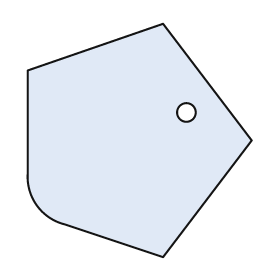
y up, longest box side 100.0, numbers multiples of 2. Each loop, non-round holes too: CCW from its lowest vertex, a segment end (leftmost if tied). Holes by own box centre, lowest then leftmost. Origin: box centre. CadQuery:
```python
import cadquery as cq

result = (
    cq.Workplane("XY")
    .moveTo(10.0, -50.0)
    .lineTo(48.0, 0.0)
    .lineTo(10.0, 50.0)
    .lineTo(-48.0, 30.0)
    .lineTo(-48.0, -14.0)
    .threePointArc((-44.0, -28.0), (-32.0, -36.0))
    .close()
    .moveTo(20.0, 12.0)
    .circle(4.0)
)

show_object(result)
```